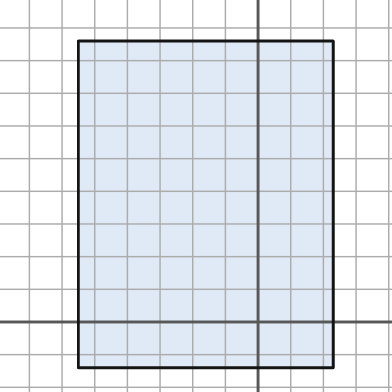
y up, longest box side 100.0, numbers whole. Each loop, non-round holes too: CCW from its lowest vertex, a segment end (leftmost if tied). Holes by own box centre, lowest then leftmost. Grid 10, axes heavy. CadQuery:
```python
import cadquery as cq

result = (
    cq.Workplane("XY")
    .moveTo(-55.0, -14.0)
    .lineTo(23.0, -14.0)
    .lineTo(23.0, 86.0)
    .lineTo(-55.0, 86.0)
    .close()
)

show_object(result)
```